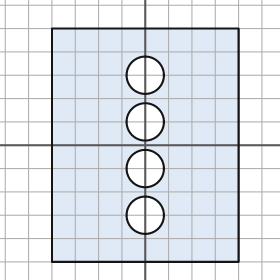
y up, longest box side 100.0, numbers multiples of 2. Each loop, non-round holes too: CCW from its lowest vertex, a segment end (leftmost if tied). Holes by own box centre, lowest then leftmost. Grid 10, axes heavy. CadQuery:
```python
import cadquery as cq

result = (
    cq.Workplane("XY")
    .moveTo(-40.0, -50.0)
    .lineTo(40.0, -50.0)
    .lineTo(40.0, 50.0)
    .lineTo(-40.0, 50.0)
    .close()
    .moveTo(0.0, -30.0)
    .circle(8.0)
    .moveTo(0.0, -10.0)
    .circle(8.0)
    .moveTo(0.0, 10.0)
    .circle(8.0)
    .moveTo(0.0, 30.0)
    .circle(8.0)
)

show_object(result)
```